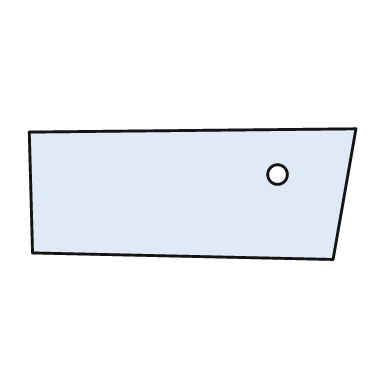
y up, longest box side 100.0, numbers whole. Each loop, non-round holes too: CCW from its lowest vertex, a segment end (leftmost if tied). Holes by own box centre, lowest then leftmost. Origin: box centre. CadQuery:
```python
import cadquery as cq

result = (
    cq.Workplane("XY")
    .moveTo(43.0, -20.0)
    .lineTo(50.0, 20.0)
    .lineTo(-50.0, 19.0)
    .lineTo(-49.0, -18.0)
    .close()
    .moveTo(26.0, 6.0)
    .circle(3.0)
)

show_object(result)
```